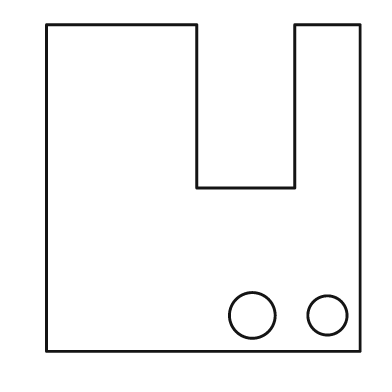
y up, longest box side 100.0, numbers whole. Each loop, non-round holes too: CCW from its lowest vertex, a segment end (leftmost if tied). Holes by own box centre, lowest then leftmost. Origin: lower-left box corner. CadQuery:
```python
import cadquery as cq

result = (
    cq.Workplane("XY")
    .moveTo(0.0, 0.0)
    .lineTo(96.0, 0.0)
    .lineTo(96.0, 100.0)
    .lineTo(76.0, 100.0)
    .lineTo(76.0, 50.0)
    .lineTo(46.0, 50.0)
    .lineTo(46.0, 100.0)
    .lineTo(0.0, 100.0)
    .close()
    .moveTo(63.0, 11.0)
    .circle(7.0)
    .moveTo(86.0, 11.0)
    .circle(6.0)
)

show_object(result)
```